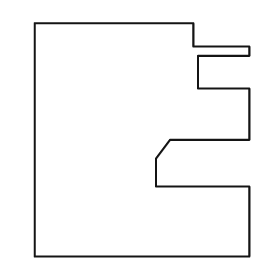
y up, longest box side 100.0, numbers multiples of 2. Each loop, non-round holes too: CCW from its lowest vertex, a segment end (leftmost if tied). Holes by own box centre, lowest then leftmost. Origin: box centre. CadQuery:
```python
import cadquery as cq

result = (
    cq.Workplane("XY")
    .moveTo(-46.0, -50.0)
    .lineTo(46.0, -50.0)
    .lineTo(46.0, -20.0)
    .lineTo(6.0, -20.0)
    .lineTo(6.0, -8.0)
    .lineTo(12.0, 0.0)
    .lineTo(46.0, 0.0)
    .lineTo(46.0, 22.0)
    .lineTo(24.0, 22.0)
    .lineTo(24.0, 36.0)
    .lineTo(46.0, 36.0)
    .lineTo(46.0, 40.0)
    .lineTo(22.0, 40.0)
    .lineTo(22.0, 50.0)
    .lineTo(-46.0, 50.0)
    .close()
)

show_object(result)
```